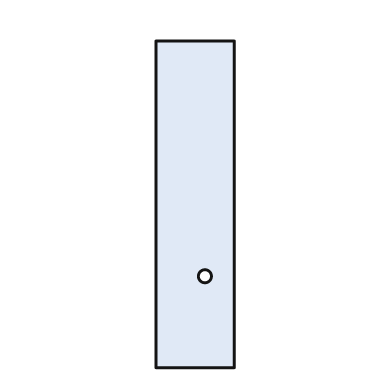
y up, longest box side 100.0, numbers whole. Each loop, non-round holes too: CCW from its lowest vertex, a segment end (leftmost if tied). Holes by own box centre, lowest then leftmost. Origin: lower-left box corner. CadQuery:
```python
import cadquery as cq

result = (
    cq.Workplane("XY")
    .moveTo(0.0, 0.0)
    .lineTo(24.0, 0.0)
    .lineTo(24.0, 100.0)
    .lineTo(0.0, 100.0)
    .close()
    .moveTo(15.0, 28.0)
    .circle(2.0)
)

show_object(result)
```